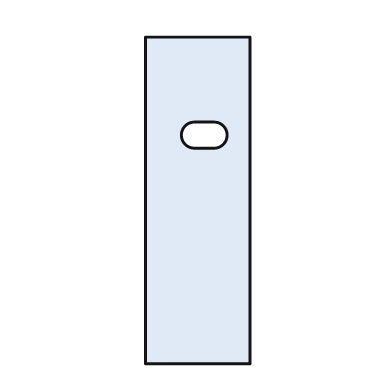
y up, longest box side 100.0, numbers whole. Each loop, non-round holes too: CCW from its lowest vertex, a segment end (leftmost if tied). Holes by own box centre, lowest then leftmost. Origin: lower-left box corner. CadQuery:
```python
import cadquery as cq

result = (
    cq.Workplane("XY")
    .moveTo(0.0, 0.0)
    .lineTo(32.0, 0.0)
    .lineTo(32.0, 100.0)
    .lineTo(0.0, 100.0)
    .close()
    .moveTo(15.0, 66.0)
    .lineTo(21.0, 66.0)
    .threePointArc((25.0, 70.0), (21.0, 74.0))
    .lineTo(15.0, 74.0)
    .threePointArc((11.0, 70.0), (15.0, 66.0))
    .close()
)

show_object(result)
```